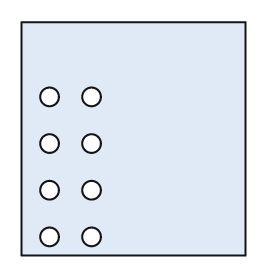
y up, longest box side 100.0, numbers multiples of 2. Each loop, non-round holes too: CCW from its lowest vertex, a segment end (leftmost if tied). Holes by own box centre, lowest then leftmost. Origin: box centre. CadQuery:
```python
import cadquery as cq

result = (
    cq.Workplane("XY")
    .moveTo(-48.0, -50.0)
    .lineTo(48.0, -50.0)
    .lineTo(48.0, 50.0)
    .lineTo(-48.0, 50.0)
    .close()
    .moveTo(-36.0, -42.0)
    .circle(4.0)
    .moveTo(-18.0, -42.0)
    .circle(4.0)
    .moveTo(-36.0, -22.0)
    .circle(4.0)
    .moveTo(-18.0, -22.0)
    .circle(4.0)
    .moveTo(-36.0, -2.0)
    .circle(4.0)
    .moveTo(-18.0, -2.0)
    .circle(4.0)
    .moveTo(-36.0, 18.0)
    .circle(4.0)
    .moveTo(-18.0, 18.0)
    .circle(4.0)
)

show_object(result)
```